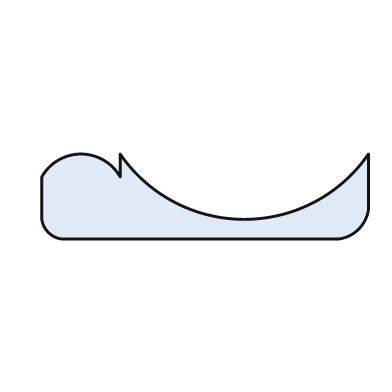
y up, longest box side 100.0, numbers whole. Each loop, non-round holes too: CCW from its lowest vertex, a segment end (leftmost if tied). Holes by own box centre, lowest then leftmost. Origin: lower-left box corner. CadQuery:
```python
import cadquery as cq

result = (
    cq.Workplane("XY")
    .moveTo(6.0, 0.0)
    .lineTo(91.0, 0.0)
    .threePointArc((97.0, 3.0), (100.0, 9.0))
    .lineTo(100.0, 26.0)
    .threePointArc((62.0, 6.0), (24.0, 26.0))
    .lineTo(24.0, 19.0)
    .threePointArc((12.0, 26.0), (0.0, 19.0))
    .lineTo(0.0, 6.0)
    .threePointArc((2.0, 2.0), (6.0, 0.0))
    .close()
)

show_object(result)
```